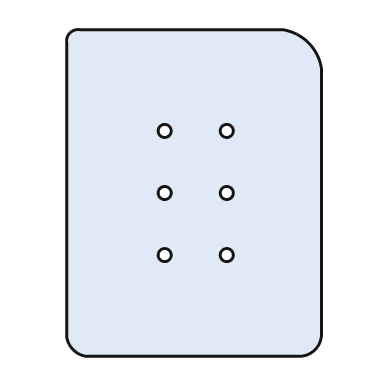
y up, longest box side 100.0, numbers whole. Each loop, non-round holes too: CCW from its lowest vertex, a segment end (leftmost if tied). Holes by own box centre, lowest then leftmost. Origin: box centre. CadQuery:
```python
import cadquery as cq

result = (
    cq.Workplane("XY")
    .moveTo(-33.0, -50.0)
    .lineTo(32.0, -50.0)
    .threePointArc((37.0, -48.0), (39.0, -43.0))
    .lineTo(39.0, 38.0)
    .threePointArc((35.0, 46.0), (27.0, 50.0))
    .lineTo(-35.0, 50.0)
    .threePointArc((-38.0, 49.0), (-39.0, 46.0))
    .lineTo(-39.0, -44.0)
    .threePointArc((-37.0, -48.0), (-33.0, -50.0))
    .close()
    .moveTo(-9.0, -19.0)
    .circle(2.0)
    .moveTo(10.0, -19.0)
    .circle(2.0)
    .moveTo(-9.0, 0.0)
    .circle(2.0)
    .moveTo(10.0, 0.0)
    .circle(2.0)
    .moveTo(-9.0, 19.0)
    .circle(2.0)
    .moveTo(10.0, 19.0)
    .circle(2.0)
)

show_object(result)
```